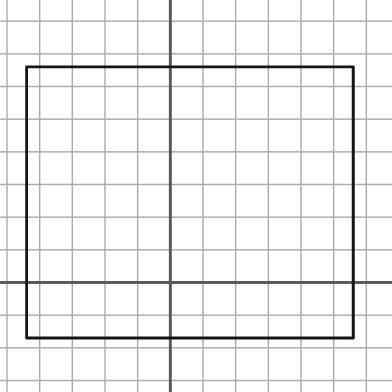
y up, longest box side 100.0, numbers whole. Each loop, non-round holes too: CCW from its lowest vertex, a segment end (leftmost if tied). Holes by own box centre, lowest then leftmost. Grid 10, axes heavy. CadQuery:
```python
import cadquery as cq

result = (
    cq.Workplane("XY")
    .moveTo(-44.0, -17.0)
    .lineTo(56.0, -17.0)
    .lineTo(56.0, 66.0)
    .lineTo(-44.0, 66.0)
    .close()
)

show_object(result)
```